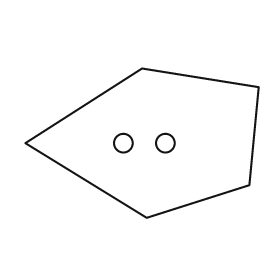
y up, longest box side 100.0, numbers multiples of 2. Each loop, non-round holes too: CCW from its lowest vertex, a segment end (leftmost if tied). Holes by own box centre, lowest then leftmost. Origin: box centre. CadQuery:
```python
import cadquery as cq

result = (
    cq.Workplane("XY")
    .moveTo(2.0, -32.0)
    .lineTo(46.0, -18.0)
    .lineTo(50.0, 24.0)
    .lineTo(0.0, 32.0)
    .lineTo(-50.0, 0.0)
    .close()
    .moveTo(-8.0, 0.0)
    .circle(4.0)
    .moveTo(10.0, 0.0)
    .circle(4.0)
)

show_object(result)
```